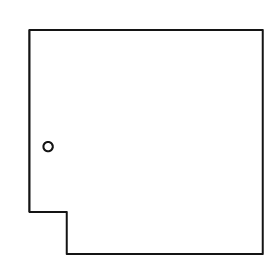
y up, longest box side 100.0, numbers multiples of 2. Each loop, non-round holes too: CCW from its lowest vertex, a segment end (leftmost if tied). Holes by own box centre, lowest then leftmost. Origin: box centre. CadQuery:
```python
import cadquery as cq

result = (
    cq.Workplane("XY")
    .moveTo(-34.0, -48.0)
    .lineTo(50.0, -48.0)
    .lineTo(50.0, 48.0)
    .lineTo(-50.0, 48.0)
    .lineTo(-50.0, -30.0)
    .lineTo(-34.0, -30.0)
    .close()
    .moveTo(-42.0, -2.0)
    .circle(2.0)
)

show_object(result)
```